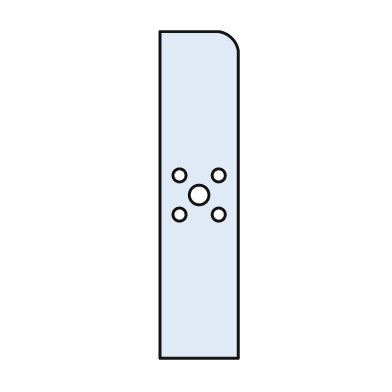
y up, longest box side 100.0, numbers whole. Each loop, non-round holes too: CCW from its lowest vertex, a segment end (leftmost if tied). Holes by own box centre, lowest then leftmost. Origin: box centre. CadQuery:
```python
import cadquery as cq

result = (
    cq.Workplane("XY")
    .moveTo(-12.0, -50.0)
    .lineTo(12.0, -50.0)
    .lineTo(12.0, 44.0)
    .threePointArc((10.0, 48.0), (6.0, 50.0))
    .lineTo(-12.0, 50.0)
    .close()
    .moveTo(-6.0, -6.0)
    .circle(2.0)
    .moveTo(6.0, -6.0)
    .circle(2.0)
    .moveTo(0.0, 0.0)
    .circle(3.0)
    .moveTo(-6.0, 6.0)
    .circle(2.0)
    .moveTo(6.0, 6.0)
    .circle(2.0)
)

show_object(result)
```